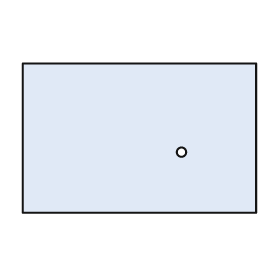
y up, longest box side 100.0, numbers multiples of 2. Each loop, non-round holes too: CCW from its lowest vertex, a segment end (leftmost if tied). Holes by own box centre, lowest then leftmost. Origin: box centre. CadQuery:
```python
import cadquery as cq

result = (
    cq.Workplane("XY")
    .moveTo(-50.0, -32.0)
    .lineTo(50.0, -32.0)
    .lineTo(50.0, 32.0)
    .lineTo(-50.0, 32.0)
    .close()
    .moveTo(18.0, -6.0)
    .circle(2.0)
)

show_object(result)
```